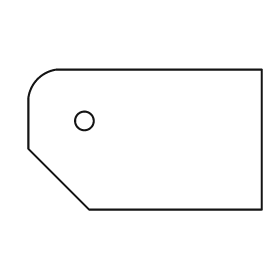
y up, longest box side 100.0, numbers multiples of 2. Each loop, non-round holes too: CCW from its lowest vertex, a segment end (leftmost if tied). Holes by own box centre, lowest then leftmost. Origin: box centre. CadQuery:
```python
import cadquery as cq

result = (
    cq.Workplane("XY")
    .moveTo(-24.0, -30.0)
    .lineTo(50.0, -30.0)
    .lineTo(50.0, 30.0)
    .lineTo(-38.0, 30.0)
    .threePointArc((-46.0, 26.0), (-50.0, 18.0))
    .lineTo(-50.0, -4.0)
    .close()
    .moveTo(-26.0, 8.0)
    .circle(4.0)
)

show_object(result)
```